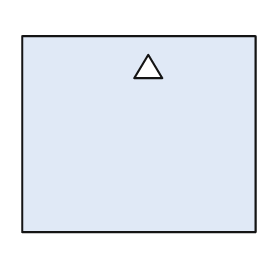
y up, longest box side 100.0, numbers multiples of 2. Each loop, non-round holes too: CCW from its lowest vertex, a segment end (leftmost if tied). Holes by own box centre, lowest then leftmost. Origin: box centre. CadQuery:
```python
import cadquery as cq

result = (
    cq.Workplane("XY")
    .moveTo(-50.0, -42.0)
    .lineTo(50.0, -42.0)
    .lineTo(50.0, 42.0)
    .lineTo(-50.0, 42.0)
    .close()
    .moveTo(-2.0, 24.0)
    .lineTo(10.0, 24.0)
    .lineTo(4.0, 34.0)
    .close()
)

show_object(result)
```